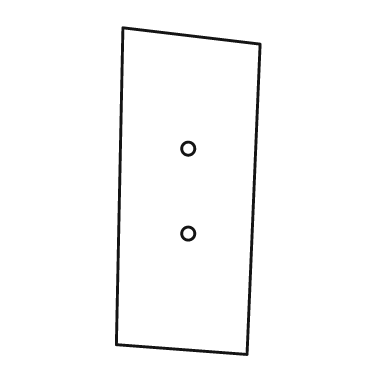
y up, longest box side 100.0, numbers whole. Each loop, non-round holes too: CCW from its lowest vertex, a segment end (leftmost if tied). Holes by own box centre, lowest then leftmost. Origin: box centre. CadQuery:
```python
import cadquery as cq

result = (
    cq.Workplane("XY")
    .moveTo(18.0, -50.0)
    .lineTo(22.0, 45.0)
    .lineTo(-20.0, 50.0)
    .lineTo(-22.0, -47.0)
    .close()
    .moveTo(0.0, -13.0)
    .circle(2.0)
    .moveTo(0.0, 13.0)
    .circle(2.0)
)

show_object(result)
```